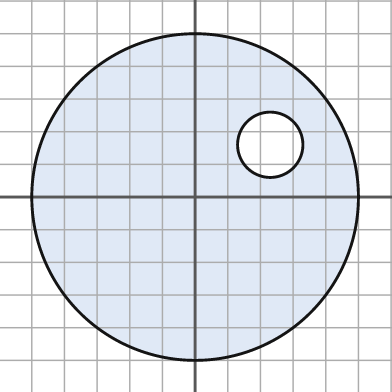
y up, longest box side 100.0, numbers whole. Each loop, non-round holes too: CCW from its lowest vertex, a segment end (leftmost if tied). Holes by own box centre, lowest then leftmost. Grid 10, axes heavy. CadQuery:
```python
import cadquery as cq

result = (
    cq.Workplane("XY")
    .moveTo(0.0, 0.0)
    .circle(50.0)
    .moveTo(23.0, 16.0)
    .circle(10.0)
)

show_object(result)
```